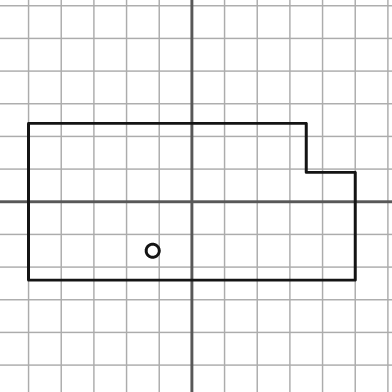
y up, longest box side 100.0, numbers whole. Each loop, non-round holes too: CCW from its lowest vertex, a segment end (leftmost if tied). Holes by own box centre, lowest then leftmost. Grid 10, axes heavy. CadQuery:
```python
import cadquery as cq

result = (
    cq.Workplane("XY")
    .moveTo(-50.0, -24.0)
    .lineTo(50.0, -24.0)
    .lineTo(50.0, 9.0)
    .lineTo(35.0, 9.0)
    .lineTo(35.0, 24.0)
    .lineTo(-50.0, 24.0)
    .close()
    .moveTo(-12.0, -15.0)
    .circle(2.0)
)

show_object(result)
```